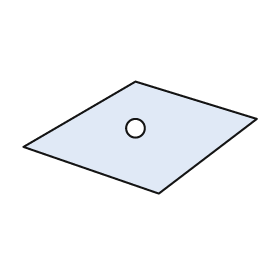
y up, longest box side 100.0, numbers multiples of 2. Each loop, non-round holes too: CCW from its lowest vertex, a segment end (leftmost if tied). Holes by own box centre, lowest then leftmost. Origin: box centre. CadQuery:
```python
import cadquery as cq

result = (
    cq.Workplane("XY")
    .moveTo(8.0, -24.0)
    .lineTo(50.0, 8.0)
    .lineTo(-2.0, 24.0)
    .lineTo(-50.0, -4.0)
    .close()
    .moveTo(-2.0, 4.0)
    .circle(4.0)
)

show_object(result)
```